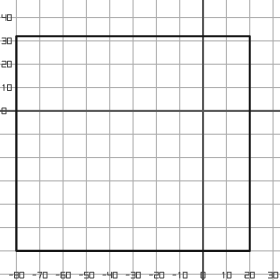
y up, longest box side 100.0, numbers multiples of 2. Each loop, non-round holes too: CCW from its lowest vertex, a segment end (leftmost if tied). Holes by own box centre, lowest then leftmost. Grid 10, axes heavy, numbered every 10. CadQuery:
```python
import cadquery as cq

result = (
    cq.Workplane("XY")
    .moveTo(-80.0, -60.0)
    .lineTo(20.0, -60.0)
    .lineTo(20.0, 32.0)
    .lineTo(-80.0, 32.0)
    .close()
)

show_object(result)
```